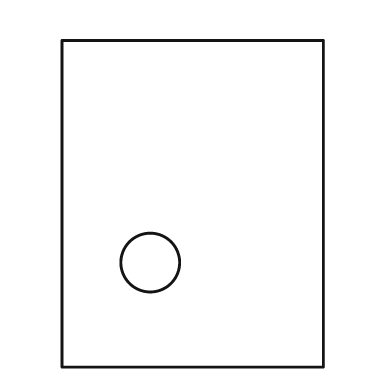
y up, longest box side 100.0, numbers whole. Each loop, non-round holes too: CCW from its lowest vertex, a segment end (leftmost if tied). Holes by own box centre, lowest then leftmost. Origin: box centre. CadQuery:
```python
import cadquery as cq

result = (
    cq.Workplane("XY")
    .moveTo(-40.0, -50.0)
    .lineTo(40.0, -50.0)
    .lineTo(40.0, 50.0)
    .lineTo(-40.0, 50.0)
    .close()
    .moveTo(-13.0, -18.0)
    .circle(9.0)
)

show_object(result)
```